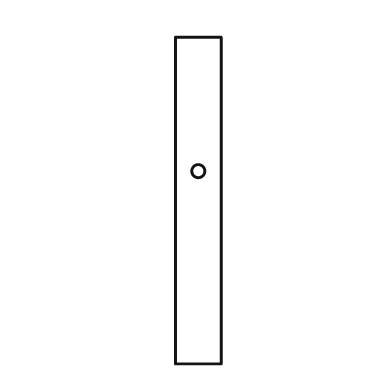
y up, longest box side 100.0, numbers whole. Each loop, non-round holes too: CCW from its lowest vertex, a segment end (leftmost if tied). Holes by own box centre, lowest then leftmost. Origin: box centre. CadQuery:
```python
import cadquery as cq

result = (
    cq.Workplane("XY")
    .moveTo(-7.0, -50.0)
    .lineTo(7.0, -50.0)
    .lineTo(7.0, 50.0)
    .lineTo(-7.0, 50.0)
    .close()
    .moveTo(0.0, 9.0)
    .circle(2.0)
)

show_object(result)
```